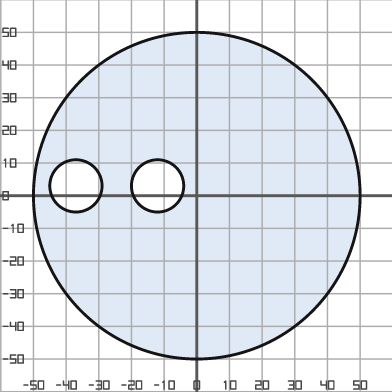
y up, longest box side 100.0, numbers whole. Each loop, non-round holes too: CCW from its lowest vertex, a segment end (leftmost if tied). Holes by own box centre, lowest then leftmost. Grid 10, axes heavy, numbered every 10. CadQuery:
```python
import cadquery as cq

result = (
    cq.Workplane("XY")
    .moveTo(0.0, 0.0)
    .circle(50.0)
    .moveTo(-37.0, 3.0)
    .circle(8.0)
    .moveTo(-12.0, 3.0)
    .circle(8.0)
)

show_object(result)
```